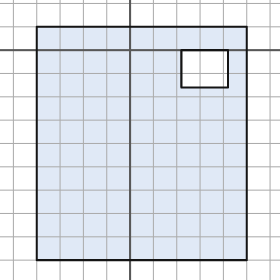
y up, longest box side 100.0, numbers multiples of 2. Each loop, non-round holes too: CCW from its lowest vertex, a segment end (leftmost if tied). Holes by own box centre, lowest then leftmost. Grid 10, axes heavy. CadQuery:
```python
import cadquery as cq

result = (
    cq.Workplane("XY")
    .moveTo(-40.0, -90.0)
    .lineTo(50.0, -90.0)
    .lineTo(50.0, 10.0)
    .lineTo(-40.0, 10.0)
    .close()
    .moveTo(22.0, -16.0)
    .lineTo(42.0, -16.0)
    .lineTo(42.0, 0.0)
    .lineTo(22.0, 0.0)
    .close()
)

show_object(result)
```